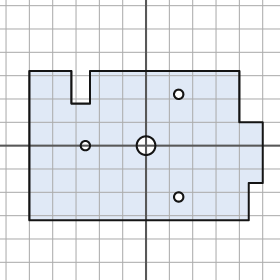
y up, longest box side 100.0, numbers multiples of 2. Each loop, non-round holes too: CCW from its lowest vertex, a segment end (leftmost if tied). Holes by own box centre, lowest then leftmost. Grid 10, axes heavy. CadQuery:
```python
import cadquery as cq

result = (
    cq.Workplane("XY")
    .moveTo(-50.0, -32.0)
    .lineTo(44.0, -32.0)
    .lineTo(44.0, -16.0)
    .lineTo(50.0, -16.0)
    .lineTo(50.0, 10.0)
    .lineTo(40.0, 10.0)
    .lineTo(40.0, 32.0)
    .lineTo(-24.0, 32.0)
    .lineTo(-24.0, 18.0)
    .lineTo(-32.0, 18.0)
    .lineTo(-32.0, 32.0)
    .lineTo(-50.0, 32.0)
    .close()
    .moveTo(14.0, -22.0)
    .circle(2.0)
    .moveTo(-26.0, 0.0)
    .circle(2.0)
    .moveTo(0.0, 0.0)
    .circle(4.0)
    .moveTo(14.0, 22.0)
    .circle(2.0)
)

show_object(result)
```